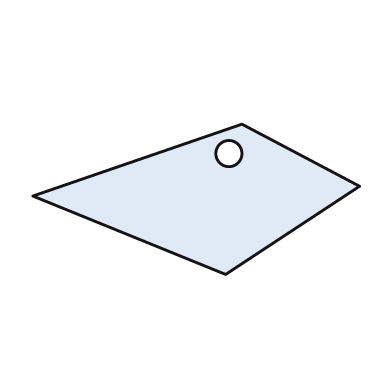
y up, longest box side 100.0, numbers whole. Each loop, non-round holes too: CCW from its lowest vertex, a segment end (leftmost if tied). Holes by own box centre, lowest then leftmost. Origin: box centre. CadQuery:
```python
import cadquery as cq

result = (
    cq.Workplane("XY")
    .moveTo(9.0, -23.0)
    .lineTo(50.0, 4.0)
    .lineTo(14.0, 23.0)
    .lineTo(-50.0, 1.0)
    .close()
    .moveTo(10.0, 14.0)
    .circle(4.0)
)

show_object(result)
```